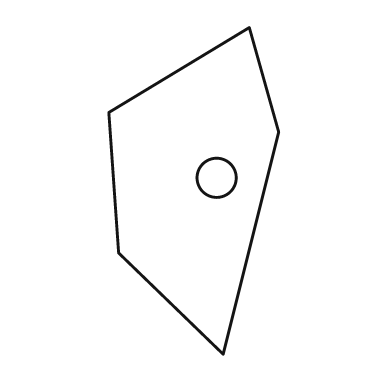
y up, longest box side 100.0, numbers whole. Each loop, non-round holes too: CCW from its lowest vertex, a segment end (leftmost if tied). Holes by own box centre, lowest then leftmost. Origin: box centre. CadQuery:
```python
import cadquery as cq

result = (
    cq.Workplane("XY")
    .moveTo(9.0, -50.0)
    .lineTo(26.0, 18.0)
    .lineTo(17.0, 50.0)
    .lineTo(-26.0, 24.0)
    .lineTo(-23.0, -19.0)
    .close()
    .moveTo(7.0, 4.0)
    .circle(6.0)
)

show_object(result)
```